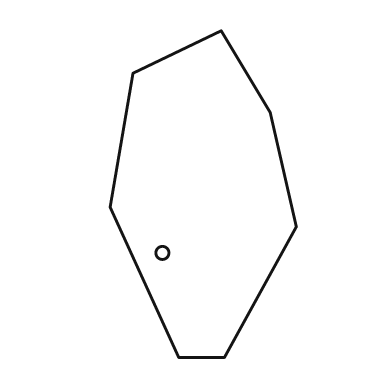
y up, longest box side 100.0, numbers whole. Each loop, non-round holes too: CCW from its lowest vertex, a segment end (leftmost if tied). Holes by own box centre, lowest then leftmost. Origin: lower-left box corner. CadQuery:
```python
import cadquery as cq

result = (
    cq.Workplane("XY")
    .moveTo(21.0, 0.0)
    .lineTo(35.0, 0.0)
    .lineTo(57.0, 40.0)
    .lineTo(49.0, 75.0)
    .lineTo(34.0, 100.0)
    .lineTo(7.0, 87.0)
    .lineTo(0.0, 46.0)
    .close()
    .moveTo(16.0, 32.0)
    .circle(2.0)
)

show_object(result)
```